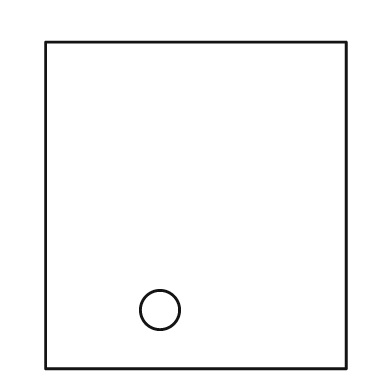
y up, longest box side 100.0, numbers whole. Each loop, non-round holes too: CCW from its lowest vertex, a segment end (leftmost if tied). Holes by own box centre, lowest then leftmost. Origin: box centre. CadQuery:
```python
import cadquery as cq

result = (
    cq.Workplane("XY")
    .moveTo(-46.0, -50.0)
    .lineTo(46.0, -50.0)
    .lineTo(46.0, 50.0)
    .lineTo(-46.0, 50.0)
    .close()
    .moveTo(-11.0, -32.0)
    .circle(6.0)
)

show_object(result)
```